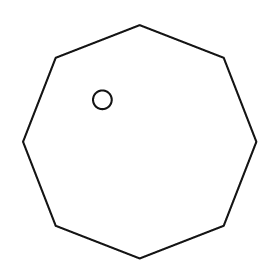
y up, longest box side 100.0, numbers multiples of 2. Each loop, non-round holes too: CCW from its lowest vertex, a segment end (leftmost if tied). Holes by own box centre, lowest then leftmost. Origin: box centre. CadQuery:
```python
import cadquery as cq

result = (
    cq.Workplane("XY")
    .moveTo(0.0, -50.0)
    .lineTo(36.0, -36.0)
    .lineTo(50.0, 0.0)
    .lineTo(36.0, 36.0)
    .lineTo(0.0, 50.0)
    .lineTo(-36.0, 36.0)
    .lineTo(-50.0, 0.0)
    .lineTo(-36.0, -36.0)
    .close()
    .moveTo(-16.0, 18.0)
    .circle(4.0)
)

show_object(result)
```